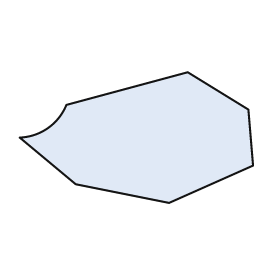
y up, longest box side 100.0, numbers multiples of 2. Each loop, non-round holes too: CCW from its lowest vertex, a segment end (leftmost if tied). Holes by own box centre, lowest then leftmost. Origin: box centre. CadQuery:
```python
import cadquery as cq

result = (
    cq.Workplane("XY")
    .moveTo(14.0, -28.0)
    .lineTo(50.0, -12.0)
    .lineTo(48.0, 12.0)
    .lineTo(22.0, 28.0)
    .lineTo(-30.0, 14.0)
    .threePointArc((-38.0, 4.0), (-50.0, 0.0))
    .lineTo(-26.0, -20.0)
    .close()
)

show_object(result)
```